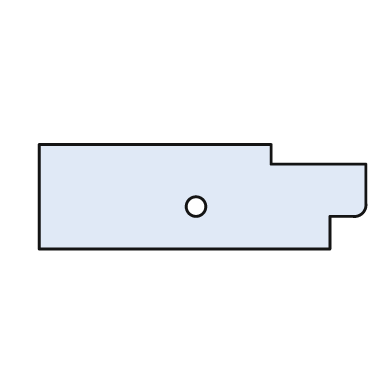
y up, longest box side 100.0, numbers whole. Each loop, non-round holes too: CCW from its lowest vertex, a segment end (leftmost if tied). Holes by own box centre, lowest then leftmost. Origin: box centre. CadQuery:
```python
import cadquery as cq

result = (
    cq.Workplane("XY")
    .moveTo(-50.0, -16.0)
    .lineTo(39.0, -16.0)
    .lineTo(39.0, -6.0)
    .lineTo(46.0, -6.0)
    .threePointArc((49.0, -5.0), (50.0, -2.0))
    .lineTo(50.0, 10.0)
    .lineTo(21.0, 10.0)
    .lineTo(21.0, 16.0)
    .lineTo(-50.0, 16.0)
    .close()
    .moveTo(-2.0, -3.0)
    .circle(3.0)
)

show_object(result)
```